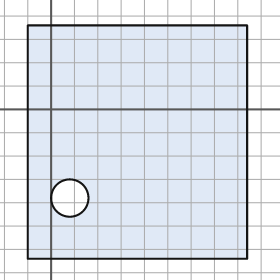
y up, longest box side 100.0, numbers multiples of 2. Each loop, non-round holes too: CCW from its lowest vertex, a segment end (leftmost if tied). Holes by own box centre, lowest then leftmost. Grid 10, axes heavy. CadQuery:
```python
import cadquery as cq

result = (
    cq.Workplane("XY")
    .moveTo(-10.0, -64.0)
    .lineTo(84.0, -64.0)
    .lineTo(84.0, 36.0)
    .lineTo(-10.0, 36.0)
    .close()
    .moveTo(8.0, -38.0)
    .circle(8.0)
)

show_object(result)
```